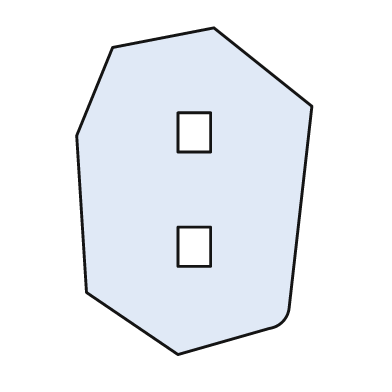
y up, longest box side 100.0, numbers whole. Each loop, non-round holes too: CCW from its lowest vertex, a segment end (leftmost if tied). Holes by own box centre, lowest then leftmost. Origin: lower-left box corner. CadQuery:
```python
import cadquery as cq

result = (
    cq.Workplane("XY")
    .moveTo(31.0, 0.0)
    .lineTo(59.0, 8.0)
    .threePointArc((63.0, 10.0), (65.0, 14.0))
    .lineTo(72.0, 76.0)
    .lineTo(42.0, 100.0)
    .lineTo(11.0, 94.0)
    .lineTo(0.0, 67.0)
    .lineTo(3.0, 19.0)
    .close()
    .moveTo(31.0, 27.0)
    .lineTo(41.0, 27.0)
    .lineTo(41.0, 39.0)
    .lineTo(31.0, 39.0)
    .close()
    .moveTo(31.0, 62.0)
    .lineTo(41.0, 62.0)
    .lineTo(41.0, 74.0)
    .lineTo(31.0, 74.0)
    .close()
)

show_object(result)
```